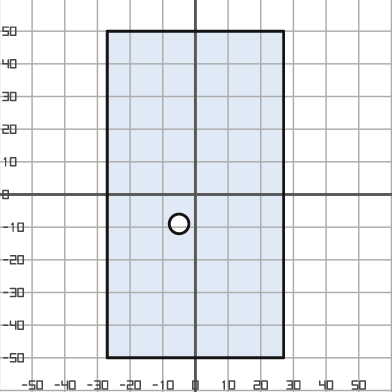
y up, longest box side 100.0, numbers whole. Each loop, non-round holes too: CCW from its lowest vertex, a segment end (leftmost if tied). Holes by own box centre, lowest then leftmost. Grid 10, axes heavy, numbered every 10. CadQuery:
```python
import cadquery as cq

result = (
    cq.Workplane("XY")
    .moveTo(-27.0, -50.0)
    .lineTo(27.0, -50.0)
    .lineTo(27.0, 50.0)
    .lineTo(-27.0, 50.0)
    .close()
    .moveTo(-5.0, -9.0)
    .circle(3.0)
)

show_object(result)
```